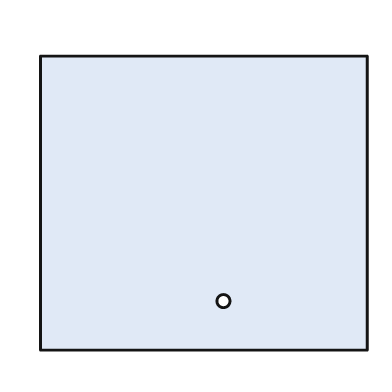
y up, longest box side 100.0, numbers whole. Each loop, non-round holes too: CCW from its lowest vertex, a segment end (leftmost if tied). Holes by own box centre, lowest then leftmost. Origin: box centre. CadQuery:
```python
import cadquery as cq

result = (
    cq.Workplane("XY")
    .moveTo(-50.0, -45.0)
    .lineTo(50.0, -45.0)
    .lineTo(50.0, 45.0)
    .lineTo(-50.0, 45.0)
    .close()
    .moveTo(6.0, -30.0)
    .circle(2.0)
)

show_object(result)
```